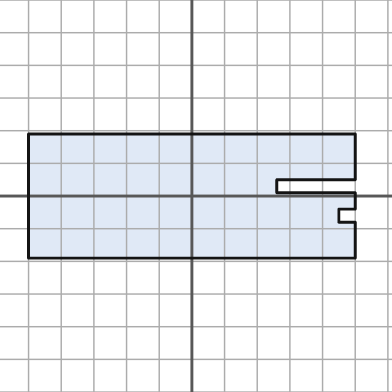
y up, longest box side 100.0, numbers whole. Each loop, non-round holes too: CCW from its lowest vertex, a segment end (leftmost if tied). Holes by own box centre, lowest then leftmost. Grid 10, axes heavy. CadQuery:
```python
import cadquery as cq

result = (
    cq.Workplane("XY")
    .moveTo(-50.0, -19.0)
    .lineTo(50.0, -19.0)
    .lineTo(50.0, -8.0)
    .lineTo(45.0, -8.0)
    .lineTo(45.0, -4.0)
    .lineTo(50.0, -4.0)
    .lineTo(50.0, 1.0)
    .lineTo(26.0, 1.0)
    .lineTo(26.0, 5.0)
    .lineTo(50.0, 5.0)
    .lineTo(50.0, 19.0)
    .lineTo(-50.0, 19.0)
    .close()
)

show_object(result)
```